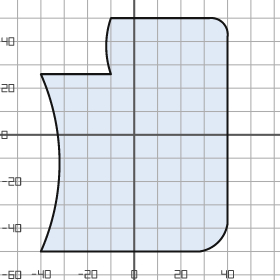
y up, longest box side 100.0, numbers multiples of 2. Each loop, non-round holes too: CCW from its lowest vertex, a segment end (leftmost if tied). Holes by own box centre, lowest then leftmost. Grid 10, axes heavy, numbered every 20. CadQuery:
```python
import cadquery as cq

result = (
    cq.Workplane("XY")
    .moveTo(-40.0, -50.0)
    .lineTo(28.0, -50.0)
    .threePointArc((36.0, -46.0), (40.0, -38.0))
    .lineTo(40.0, 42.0)
    .threePointArc((38.0, 48.0), (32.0, 50.0))
    .lineTo(-10.0, 50.0)
    .threePointArc((-12.0, 38.0), (-10.0, 26.0))
    .lineTo(-40.0, 26.0)
    .threePointArc((-32.0, -12.0), (-40.0, -50.0))
    .close()
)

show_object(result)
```